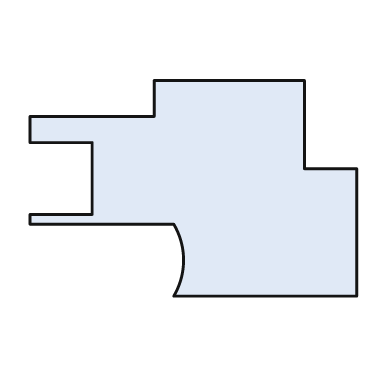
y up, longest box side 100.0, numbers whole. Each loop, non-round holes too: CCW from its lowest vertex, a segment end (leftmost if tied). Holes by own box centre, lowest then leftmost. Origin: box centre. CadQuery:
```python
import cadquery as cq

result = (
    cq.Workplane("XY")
    .moveTo(-6.0, -33.0)
    .lineTo(50.0, -33.0)
    .lineTo(50.0, 6.0)
    .lineTo(34.0, 6.0)
    .lineTo(34.0, 33.0)
    .lineTo(-12.0, 33.0)
    .lineTo(-12.0, 22.0)
    .lineTo(-50.0, 22.0)
    .lineTo(-50.0, 14.0)
    .lineTo(-31.0, 14.0)
    .lineTo(-31.0, -8.0)
    .lineTo(-50.0, -8.0)
    .lineTo(-50.0, -11.0)
    .lineTo(-6.0, -11.0)
    .threePointArc((-3.0, -22.0), (-6.0, -33.0))
    .close()
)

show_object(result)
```